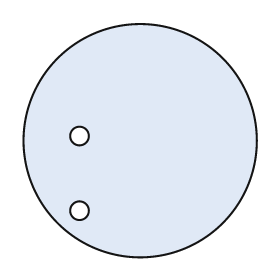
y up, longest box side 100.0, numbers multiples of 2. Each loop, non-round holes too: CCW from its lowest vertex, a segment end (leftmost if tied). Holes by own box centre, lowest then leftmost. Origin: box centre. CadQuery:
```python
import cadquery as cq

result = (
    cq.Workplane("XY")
    .moveTo(0.0, 0.0)
    .circle(50.0)
    .moveTo(-26.0, -30.0)
    .circle(4.0)
    .moveTo(-26.0, 2.0)
    .circle(4.0)
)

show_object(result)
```